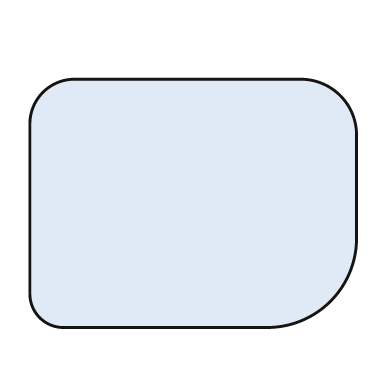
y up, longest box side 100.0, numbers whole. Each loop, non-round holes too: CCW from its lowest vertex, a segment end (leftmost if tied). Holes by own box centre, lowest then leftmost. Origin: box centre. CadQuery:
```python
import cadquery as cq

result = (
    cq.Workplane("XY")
    .moveTo(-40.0, -38.0)
    .lineTo(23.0, -38.0)
    .threePointArc((42.0, -30.0), (50.0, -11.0))
    .lineTo(50.0, 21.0)
    .threePointArc((45.0, 33.0), (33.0, 38.0))
    .lineTo(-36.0, 38.0)
    .threePointArc((-46.0, 34.0), (-50.0, 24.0))
    .lineTo(-50.0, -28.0)
    .threePointArc((-47.0, -35.0), (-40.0, -38.0))
    .close()
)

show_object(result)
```